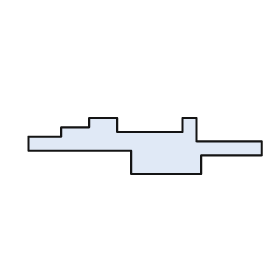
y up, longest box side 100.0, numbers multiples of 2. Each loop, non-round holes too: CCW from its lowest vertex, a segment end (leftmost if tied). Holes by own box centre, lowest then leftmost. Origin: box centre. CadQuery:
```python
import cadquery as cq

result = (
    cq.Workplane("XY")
    .moveTo(-6.0, -12.0)
    .lineTo(24.0, -12.0)
    .lineTo(24.0, -4.0)
    .lineTo(50.0, -4.0)
    .lineTo(50.0, 2.0)
    .lineTo(22.0, 2.0)
    .lineTo(22.0, 12.0)
    .lineTo(16.0, 12.0)
    .lineTo(16.0, 6.0)
    .lineTo(-12.0, 6.0)
    .lineTo(-12.0, 12.0)
    .lineTo(-24.0, 12.0)
    .lineTo(-24.0, 8.0)
    .lineTo(-36.0, 8.0)
    .lineTo(-36.0, 4.0)
    .lineTo(-50.0, 4.0)
    .lineTo(-50.0, -2.0)
    .lineTo(-6.0, -2.0)
    .close()
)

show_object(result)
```